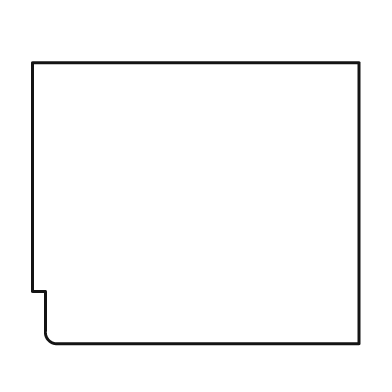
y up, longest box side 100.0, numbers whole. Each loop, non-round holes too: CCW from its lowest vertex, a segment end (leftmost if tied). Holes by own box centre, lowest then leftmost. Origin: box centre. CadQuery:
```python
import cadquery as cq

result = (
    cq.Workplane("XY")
    .moveTo(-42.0, -43.0)
    .lineTo(50.0, -43.0)
    .lineTo(50.0, 43.0)
    .lineTo(-50.0, 43.0)
    .lineTo(-50.0, -27.0)
    .lineTo(-46.0, -27.0)
    .lineTo(-46.0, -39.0)
    .threePointArc((-45.0, -42.0), (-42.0, -43.0))
    .close()
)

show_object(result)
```